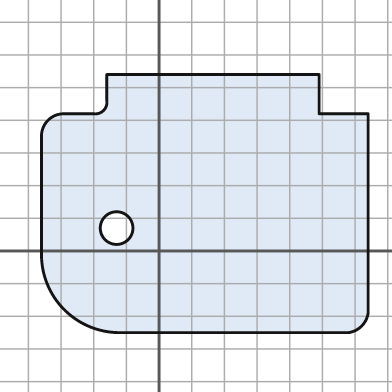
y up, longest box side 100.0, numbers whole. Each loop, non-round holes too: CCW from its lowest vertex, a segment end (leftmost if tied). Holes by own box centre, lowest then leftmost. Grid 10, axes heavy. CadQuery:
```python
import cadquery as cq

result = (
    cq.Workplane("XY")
    .moveTo(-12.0, -25.0)
    .lineTo(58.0, -25.0)
    .threePointArc((62.0, -23.0), (64.0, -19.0))
    .lineTo(64.0, 42.0)
    .lineTo(49.0, 42.0)
    .lineTo(49.0, 54.0)
    .lineTo(-16.0, 54.0)
    .lineTo(-16.0, 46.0)
    .threePointArc((-17.0, 43.0), (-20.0, 42.0))
    .lineTo(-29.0, 42.0)
    .threePointArc((-34.0, 40.0), (-36.0, 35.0))
    .lineTo(-36.0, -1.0)
    .threePointArc((-29.0, -18.0), (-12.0, -25.0))
    .close()
    .moveTo(-13.0, 7.0)
    .circle(5.0)
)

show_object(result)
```